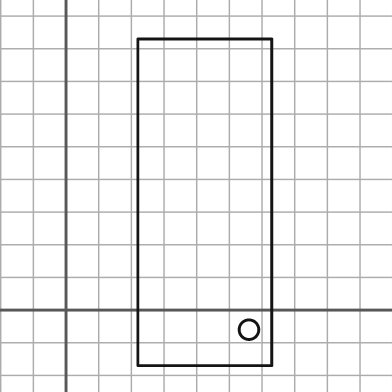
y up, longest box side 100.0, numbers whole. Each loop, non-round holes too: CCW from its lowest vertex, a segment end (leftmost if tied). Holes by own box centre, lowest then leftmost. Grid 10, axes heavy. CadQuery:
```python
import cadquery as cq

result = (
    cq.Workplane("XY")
    .moveTo(22.0, -17.0)
    .lineTo(63.0, -17.0)
    .lineTo(63.0, 83.0)
    .lineTo(22.0, 83.0)
    .close()
    .moveTo(56.0, -6.0)
    .circle(3.0)
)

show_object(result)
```